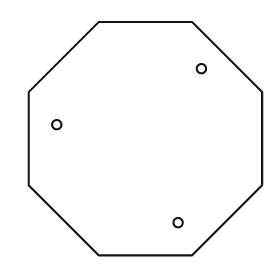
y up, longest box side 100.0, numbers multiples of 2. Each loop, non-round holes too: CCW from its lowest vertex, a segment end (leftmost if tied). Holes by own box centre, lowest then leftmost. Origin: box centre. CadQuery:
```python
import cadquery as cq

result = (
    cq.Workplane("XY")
    .moveTo(-20.0, -50.0)
    .lineTo(20.0, -50.0)
    .lineTo(50.0, -20.0)
    .lineTo(50.0, 20.0)
    .lineTo(20.0, 50.0)
    .lineTo(-20.0, 50.0)
    .lineTo(-50.0, 20.0)
    .lineTo(-50.0, -20.0)
    .close()
    .moveTo(14.0, -36.0)
    .circle(2.0)
    .moveTo(-38.0, 6.0)
    .circle(2.0)
    .moveTo(24.0, 30.0)
    .circle(2.0)
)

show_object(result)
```